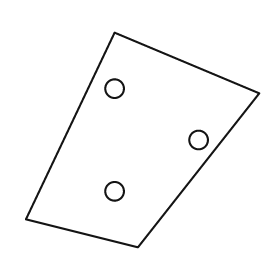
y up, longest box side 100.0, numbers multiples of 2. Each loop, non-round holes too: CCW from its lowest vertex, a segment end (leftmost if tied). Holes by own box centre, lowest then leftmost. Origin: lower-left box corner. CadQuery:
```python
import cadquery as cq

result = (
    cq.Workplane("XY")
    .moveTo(48.0, 0.0)
    .lineTo(100.0, 66.0)
    .lineTo(38.0, 92.0)
    .lineTo(0.0, 12.0)
    .close()
    .moveTo(38.0, 24.0)
    .circle(4.0)
    .moveTo(74.0, 46.0)
    .circle(4.0)
    .moveTo(38.0, 68.0)
    .circle(4.0)
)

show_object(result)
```